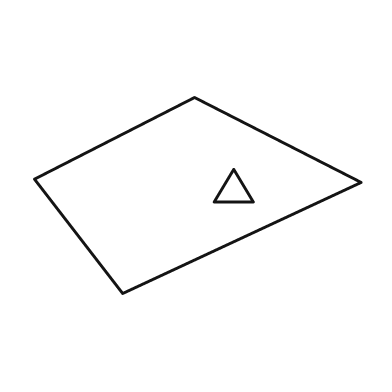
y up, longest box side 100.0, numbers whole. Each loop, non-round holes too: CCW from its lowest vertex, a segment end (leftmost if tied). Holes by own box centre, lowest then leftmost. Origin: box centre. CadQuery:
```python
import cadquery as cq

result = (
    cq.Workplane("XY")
    .moveTo(-23.0, -30.0)
    .lineTo(50.0, 4.0)
    .lineTo(-1.0, 30.0)
    .lineTo(-50.0, 5.0)
    .close()
    .moveTo(5.0, -2.0)
    .lineTo(17.0, -2.0)
    .lineTo(11.0, 8.0)
    .close()
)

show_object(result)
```